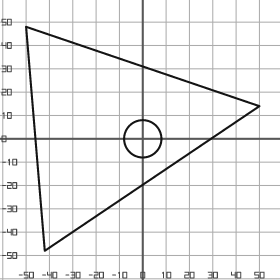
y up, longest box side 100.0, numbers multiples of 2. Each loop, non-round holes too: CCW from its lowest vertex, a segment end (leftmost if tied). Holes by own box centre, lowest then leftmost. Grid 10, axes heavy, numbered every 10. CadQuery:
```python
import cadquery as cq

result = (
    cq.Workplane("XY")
    .moveTo(-42.0, -48.0)
    .lineTo(50.0, 14.0)
    .lineTo(-50.0, 48.0)
    .close()
    .moveTo(0.0, 0.0)
    .circle(8.0)
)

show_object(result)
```